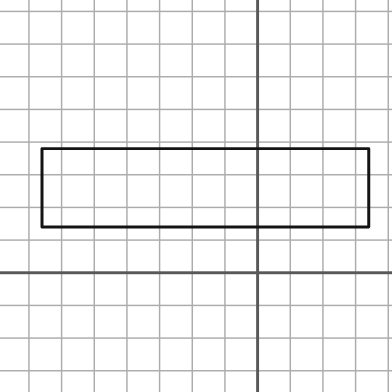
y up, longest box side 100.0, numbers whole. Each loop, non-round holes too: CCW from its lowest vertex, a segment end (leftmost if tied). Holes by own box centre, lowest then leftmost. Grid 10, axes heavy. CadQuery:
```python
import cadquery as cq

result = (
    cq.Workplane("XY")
    .moveTo(-66.0, 14.0)
    .lineTo(34.0, 14.0)
    .lineTo(34.0, 38.0)
    .lineTo(-66.0, 38.0)
    .close()
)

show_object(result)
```